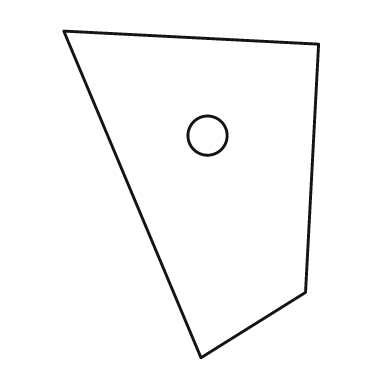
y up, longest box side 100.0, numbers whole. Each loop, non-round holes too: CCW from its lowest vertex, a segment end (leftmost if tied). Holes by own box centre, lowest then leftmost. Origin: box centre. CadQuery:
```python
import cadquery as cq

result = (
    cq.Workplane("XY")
    .moveTo(3.0, -50.0)
    .lineTo(35.0, -30.0)
    .lineTo(39.0, 46.0)
    .lineTo(-39.0, 50.0)
    .close()
    .moveTo(5.0, 18.0)
    .circle(6.0)
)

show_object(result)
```